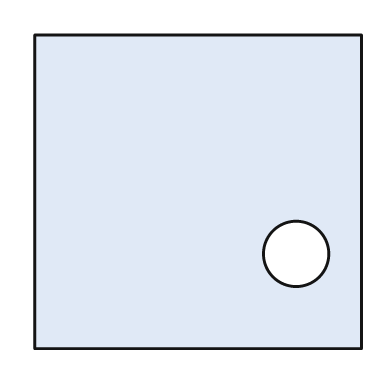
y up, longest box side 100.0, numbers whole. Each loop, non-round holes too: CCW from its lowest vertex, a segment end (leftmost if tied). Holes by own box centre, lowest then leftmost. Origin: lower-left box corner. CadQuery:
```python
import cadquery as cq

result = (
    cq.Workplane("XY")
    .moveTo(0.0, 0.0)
    .lineTo(100.0, 0.0)
    .lineTo(100.0, 96.0)
    .lineTo(0.0, 96.0)
    .close()
    .moveTo(80.0, 29.0)
    .circle(10.0)
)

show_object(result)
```